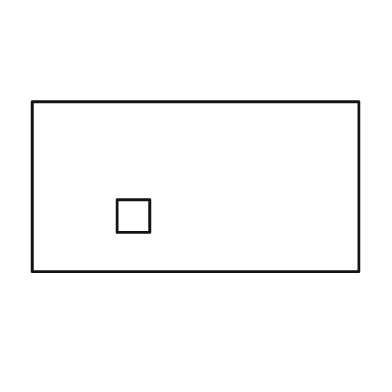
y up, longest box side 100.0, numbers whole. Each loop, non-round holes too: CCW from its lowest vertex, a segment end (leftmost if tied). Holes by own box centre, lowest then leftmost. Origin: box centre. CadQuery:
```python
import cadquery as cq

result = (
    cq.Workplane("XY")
    .moveTo(-50.0, -26.0)
    .lineTo(50.0, -26.0)
    .lineTo(50.0, 26.0)
    .lineTo(-50.0, 26.0)
    .close()
    .moveTo(-24.0, -14.0)
    .lineTo(-14.0, -14.0)
    .lineTo(-14.0, -4.0)
    .lineTo(-24.0, -4.0)
    .close()
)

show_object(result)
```